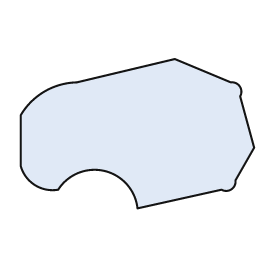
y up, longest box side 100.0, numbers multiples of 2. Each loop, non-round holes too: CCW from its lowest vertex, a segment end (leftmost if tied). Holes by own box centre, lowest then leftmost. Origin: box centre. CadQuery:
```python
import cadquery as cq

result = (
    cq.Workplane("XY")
    .moveTo(0.0, -32.0)
    .lineTo(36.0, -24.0)
    .threePointArc((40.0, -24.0), (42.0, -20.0))
    .lineTo(50.0, -6.0)
    .lineTo(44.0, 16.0)
    .threePointArc((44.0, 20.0), (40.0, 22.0))
    .lineTo(16.0, 32.0)
    .lineTo(-26.0, 22.0)
    .threePointArc((-40.0, 18.0), (-50.0, 8.0))
    .lineTo(-50.0, -14.0)
    .threePointArc((-44.0, -22.0), (-34.0, -24.0))
    .threePointArc((-14.0, -16.0), (0.0, -32.0))
    .close()
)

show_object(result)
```